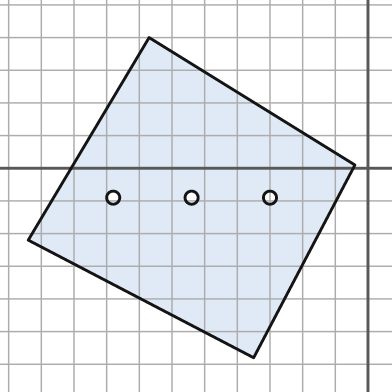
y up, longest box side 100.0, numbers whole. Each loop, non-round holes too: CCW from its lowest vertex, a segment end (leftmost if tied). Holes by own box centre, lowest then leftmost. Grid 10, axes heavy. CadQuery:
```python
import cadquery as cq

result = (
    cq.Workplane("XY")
    .moveTo(-35.0, -58.0)
    .lineTo(-4.0, 1.0)
    .lineTo(-67.0, 40.0)
    .lineTo(-104.0, -22.0)
    .close()
    .moveTo(-78.0, -9.0)
    .circle(2.0)
    .moveTo(-54.0, -9.0)
    .circle(2.0)
    .moveTo(-30.0, -9.0)
    .circle(2.0)
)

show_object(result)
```